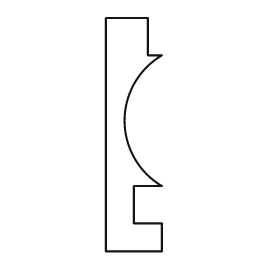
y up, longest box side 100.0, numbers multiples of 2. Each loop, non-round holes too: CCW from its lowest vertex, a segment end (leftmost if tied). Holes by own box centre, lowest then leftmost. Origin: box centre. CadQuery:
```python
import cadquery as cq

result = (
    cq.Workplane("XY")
    .moveTo(-12.0, -50.0)
    .lineTo(12.0, -50.0)
    .lineTo(12.0, -38.0)
    .lineTo(0.0, -38.0)
    .lineTo(0.0, -22.0)
    .lineTo(12.0, -22.0)
    .threePointArc((-4.0, 6.0), (12.0, 34.0))
    .lineTo(6.0, 34.0)
    .lineTo(6.0, 50.0)
    .lineTo(-12.0, 50.0)
    .close()
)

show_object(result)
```